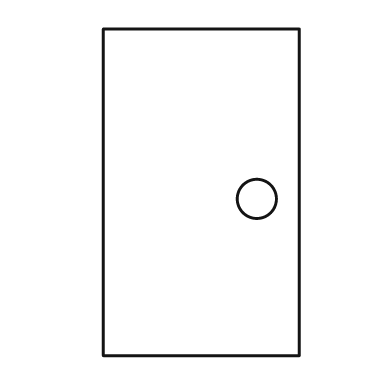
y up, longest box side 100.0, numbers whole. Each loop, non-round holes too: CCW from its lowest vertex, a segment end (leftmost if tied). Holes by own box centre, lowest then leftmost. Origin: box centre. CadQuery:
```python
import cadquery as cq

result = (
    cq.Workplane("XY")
    .moveTo(-30.0, -50.0)
    .lineTo(30.0, -50.0)
    .lineTo(30.0, 50.0)
    .lineTo(-30.0, 50.0)
    .close()
    .moveTo(17.0, -2.0)
    .circle(6.0)
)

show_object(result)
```